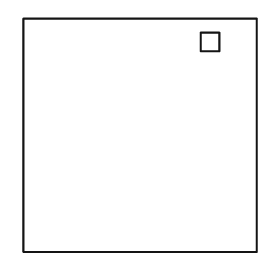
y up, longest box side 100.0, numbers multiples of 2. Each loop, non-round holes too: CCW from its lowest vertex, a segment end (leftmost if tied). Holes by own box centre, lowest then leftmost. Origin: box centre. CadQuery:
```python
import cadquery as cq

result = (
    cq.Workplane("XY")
    .moveTo(-50.0, -50.0)
    .lineTo(50.0, -50.0)
    .lineTo(50.0, 50.0)
    .lineTo(-50.0, 50.0)
    .close()
    .moveTo(26.0, 36.0)
    .lineTo(34.0, 36.0)
    .lineTo(34.0, 44.0)
    .lineTo(26.0, 44.0)
    .close()
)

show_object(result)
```